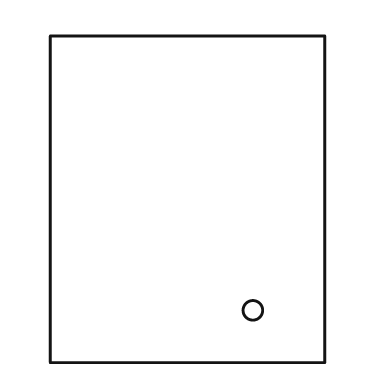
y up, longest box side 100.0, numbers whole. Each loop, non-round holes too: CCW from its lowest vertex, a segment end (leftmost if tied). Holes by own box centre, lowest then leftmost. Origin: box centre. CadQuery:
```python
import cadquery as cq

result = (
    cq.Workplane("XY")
    .moveTo(-42.0, -50.0)
    .lineTo(42.0, -50.0)
    .lineTo(42.0, 50.0)
    .lineTo(-42.0, 50.0)
    .close()
    .moveTo(20.0, -34.0)
    .circle(3.0)
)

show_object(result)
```